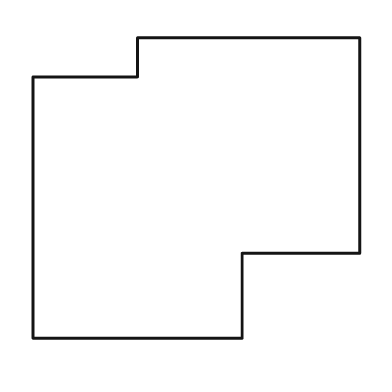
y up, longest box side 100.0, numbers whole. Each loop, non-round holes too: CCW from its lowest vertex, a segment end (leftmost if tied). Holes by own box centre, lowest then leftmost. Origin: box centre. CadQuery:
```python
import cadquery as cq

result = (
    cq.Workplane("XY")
    .moveTo(-50.0, -46.0)
    .lineTo(14.0, -46.0)
    .lineTo(14.0, -20.0)
    .lineTo(50.0, -20.0)
    .lineTo(50.0, 46.0)
    .lineTo(-18.0, 46.0)
    .lineTo(-18.0, 34.0)
    .lineTo(-50.0, 34.0)
    .close()
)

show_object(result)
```